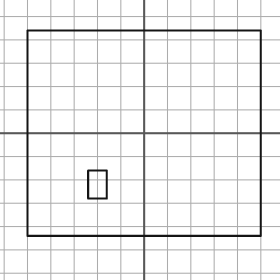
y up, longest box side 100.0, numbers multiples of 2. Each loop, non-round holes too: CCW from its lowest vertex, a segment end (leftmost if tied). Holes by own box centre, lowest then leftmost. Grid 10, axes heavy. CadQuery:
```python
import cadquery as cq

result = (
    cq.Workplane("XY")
    .moveTo(-50.0, -44.0)
    .lineTo(50.0, -44.0)
    .lineTo(50.0, 44.0)
    .lineTo(-50.0, 44.0)
    .close()
    .moveTo(-24.0, -28.0)
    .lineTo(-16.0, -28.0)
    .lineTo(-16.0, -16.0)
    .lineTo(-24.0, -16.0)
    .close()
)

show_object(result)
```